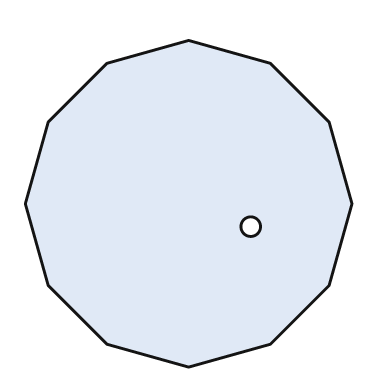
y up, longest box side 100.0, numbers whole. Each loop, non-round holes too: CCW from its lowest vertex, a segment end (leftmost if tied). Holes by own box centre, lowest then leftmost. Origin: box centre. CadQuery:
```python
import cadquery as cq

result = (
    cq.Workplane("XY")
    .moveTo(0.0, -50.0)
    .lineTo(25.0, -43.0)
    .lineTo(43.0, -25.0)
    .lineTo(50.0, 0.0)
    .lineTo(43.0, 25.0)
    .lineTo(25.0, 43.0)
    .lineTo(0.0, 50.0)
    .lineTo(-25.0, 43.0)
    .lineTo(-43.0, 25.0)
    .lineTo(-50.0, 0.0)
    .lineTo(-43.0, -25.0)
    .lineTo(-25.0, -43.0)
    .close()
    .moveTo(19.0, -7.0)
    .circle(3.0)
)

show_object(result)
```